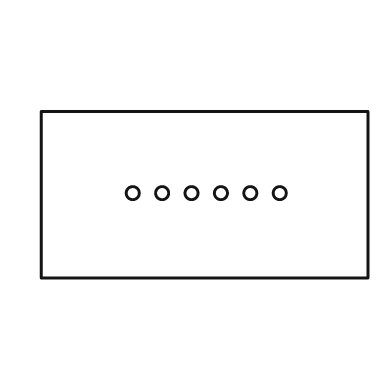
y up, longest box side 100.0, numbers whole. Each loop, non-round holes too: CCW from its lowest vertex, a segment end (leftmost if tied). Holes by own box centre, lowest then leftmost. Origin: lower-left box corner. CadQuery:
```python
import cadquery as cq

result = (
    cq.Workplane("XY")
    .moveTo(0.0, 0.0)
    .lineTo(100.0, 0.0)
    .lineTo(100.0, 51.0)
    .lineTo(0.0, 51.0)
    .close()
    .moveTo(28.0, 26.0)
    .circle(2.0)
    .moveTo(37.0, 26.0)
    .circle(2.0)
    .moveTo(46.0, 26.0)
    .circle(2.0)
    .moveTo(55.0, 26.0)
    .circle(2.0)
    .moveTo(64.0, 26.0)
    .circle(2.0)
    .moveTo(73.0, 26.0)
    .circle(2.0)
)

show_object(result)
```